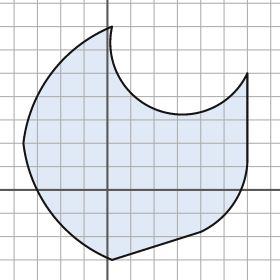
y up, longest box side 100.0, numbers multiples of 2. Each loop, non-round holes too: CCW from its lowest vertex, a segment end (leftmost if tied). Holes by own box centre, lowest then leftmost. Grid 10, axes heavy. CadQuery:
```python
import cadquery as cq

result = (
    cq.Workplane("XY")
    .moveTo(2.0, -30.0)
    .lineTo(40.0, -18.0)
    .threePointArc((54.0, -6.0), (60.0, 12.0))
    .lineTo(60.0, 50.0)
    .threePointArc((22.0, 34.0), (2.0, 70.0))
    .threePointArc((-24.0, 50.0), (-36.0, 20.0))
    .threePointArc((-24.0, -10.0), (2.0, -30.0))
    .close()
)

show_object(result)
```